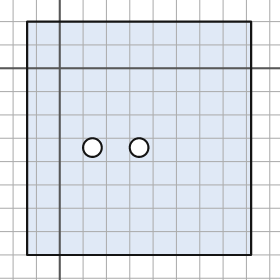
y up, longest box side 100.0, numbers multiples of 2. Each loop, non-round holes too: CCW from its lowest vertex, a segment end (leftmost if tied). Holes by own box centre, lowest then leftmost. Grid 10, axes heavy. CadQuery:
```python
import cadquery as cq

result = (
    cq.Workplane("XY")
    .moveTo(-14.0, -80.0)
    .lineTo(82.0, -80.0)
    .lineTo(82.0, 20.0)
    .lineTo(-14.0, 20.0)
    .close()
    .moveTo(14.0, -34.0)
    .circle(4.0)
    .moveTo(34.0, -34.0)
    .circle(4.0)
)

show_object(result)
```